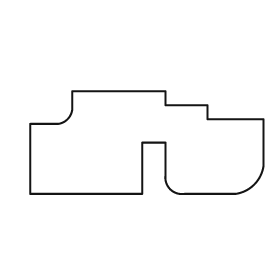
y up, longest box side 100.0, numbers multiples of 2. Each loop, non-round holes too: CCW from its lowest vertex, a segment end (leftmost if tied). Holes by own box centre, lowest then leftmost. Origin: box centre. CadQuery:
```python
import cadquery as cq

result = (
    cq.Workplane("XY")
    .moveTo(-50.0, -22.0)
    .lineTo(-2.0, -22.0)
    .lineTo(-2.0, 0.0)
    .lineTo(8.0, 0.0)
    .lineTo(8.0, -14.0)
    .threePointArc((10.0, -20.0), (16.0, -22.0))
    .lineTo(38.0, -22.0)
    .threePointArc((46.0, -18.0), (50.0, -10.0))
    .lineTo(50.0, 10.0)
    .lineTo(26.0, 10.0)
    .lineTo(26.0, 16.0)
    .lineTo(8.0, 16.0)
    .lineTo(8.0, 22.0)
    .lineTo(-32.0, 22.0)
    .lineTo(-32.0, 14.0)
    .threePointArc((-34.0, 10.0), (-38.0, 8.0))
    .lineTo(-50.0, 8.0)
    .close()
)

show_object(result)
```